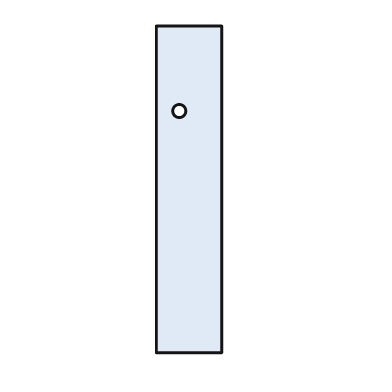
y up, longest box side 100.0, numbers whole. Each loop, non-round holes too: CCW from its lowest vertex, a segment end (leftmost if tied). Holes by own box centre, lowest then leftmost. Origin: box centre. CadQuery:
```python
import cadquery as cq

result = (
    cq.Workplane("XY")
    .moveTo(-10.0, -50.0)
    .lineTo(10.0, -50.0)
    .lineTo(10.0, 50.0)
    .lineTo(-10.0, 50.0)
    .close()
    .moveTo(-3.0, 24.0)
    .circle(2.0)
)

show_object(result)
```